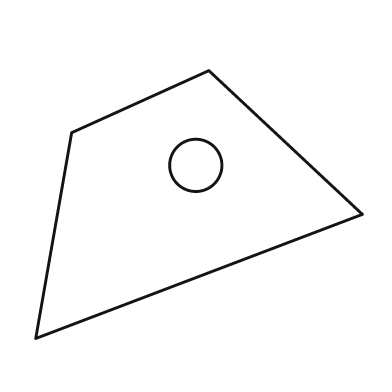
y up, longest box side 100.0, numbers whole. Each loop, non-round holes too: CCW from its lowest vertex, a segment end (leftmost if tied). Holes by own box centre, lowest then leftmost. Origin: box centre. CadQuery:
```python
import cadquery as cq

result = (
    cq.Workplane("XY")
    .moveTo(-50.0, -41.0)
    .lineTo(50.0, -3.0)
    .lineTo(3.0, 41.0)
    .lineTo(-39.0, 22.0)
    .close()
    .moveTo(-1.0, 12.0)
    .circle(8.0)
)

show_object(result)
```